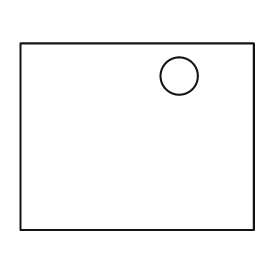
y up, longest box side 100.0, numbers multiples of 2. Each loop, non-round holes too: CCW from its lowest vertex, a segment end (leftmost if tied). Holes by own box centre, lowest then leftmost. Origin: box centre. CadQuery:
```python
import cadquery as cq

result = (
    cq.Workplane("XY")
    .moveTo(-50.0, -40.0)
    .lineTo(50.0, -40.0)
    .lineTo(50.0, 40.0)
    .lineTo(-50.0, 40.0)
    .close()
    .moveTo(18.0, 26.0)
    .circle(8.0)
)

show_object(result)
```